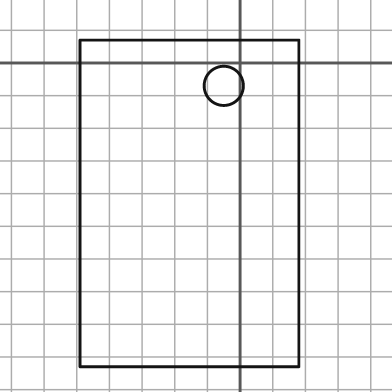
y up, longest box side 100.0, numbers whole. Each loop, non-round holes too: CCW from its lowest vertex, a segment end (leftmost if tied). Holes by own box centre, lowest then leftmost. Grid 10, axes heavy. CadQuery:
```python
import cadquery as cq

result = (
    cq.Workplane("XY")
    .moveTo(-49.0, -93.0)
    .lineTo(18.0, -93.0)
    .lineTo(18.0, 7.0)
    .lineTo(-49.0, 7.0)
    .close()
    .moveTo(-5.0, -7.0)
    .circle(6.0)
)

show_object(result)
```